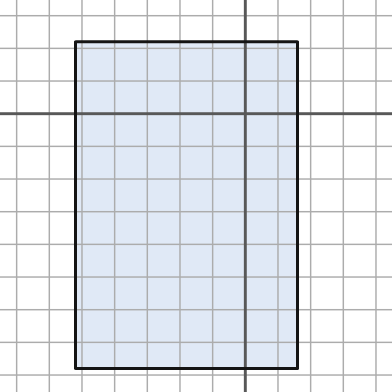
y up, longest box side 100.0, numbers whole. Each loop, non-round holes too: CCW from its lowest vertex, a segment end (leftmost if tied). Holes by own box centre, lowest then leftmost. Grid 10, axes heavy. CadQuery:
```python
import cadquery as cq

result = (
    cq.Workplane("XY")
    .moveTo(-52.0, -78.0)
    .lineTo(16.0, -78.0)
    .lineTo(16.0, 22.0)
    .lineTo(-52.0, 22.0)
    .close()
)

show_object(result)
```